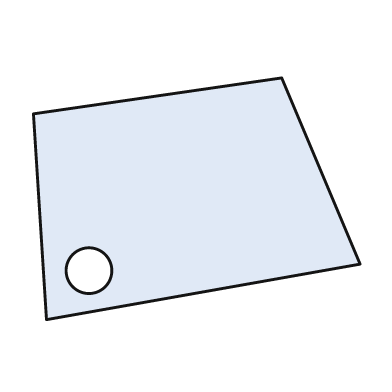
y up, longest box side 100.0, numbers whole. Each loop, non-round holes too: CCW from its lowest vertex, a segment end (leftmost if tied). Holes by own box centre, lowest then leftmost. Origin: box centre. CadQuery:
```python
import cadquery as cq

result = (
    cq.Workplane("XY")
    .moveTo(-46.0, -37.0)
    .lineTo(50.0, -20.0)
    .lineTo(26.0, 37.0)
    .lineTo(-50.0, 26.0)
    .close()
    .moveTo(-33.0, -22.0)
    .circle(7.0)
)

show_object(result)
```